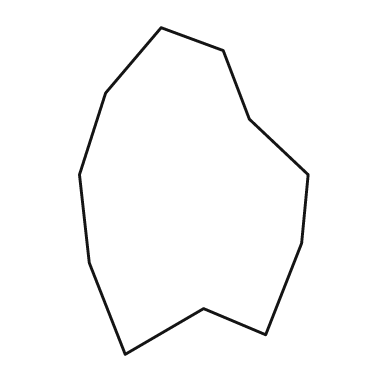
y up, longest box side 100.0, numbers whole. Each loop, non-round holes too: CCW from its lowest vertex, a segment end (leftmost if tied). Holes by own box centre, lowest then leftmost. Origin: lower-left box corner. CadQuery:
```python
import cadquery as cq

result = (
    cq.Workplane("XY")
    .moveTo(14.0, 0.0)
    .lineTo(38.0, 14.0)
    .lineTo(57.0, 6.0)
    .lineTo(68.0, 34.0)
    .lineTo(70.0, 55.0)
    .lineTo(52.0, 72.0)
    .lineTo(44.0, 93.0)
    .lineTo(25.0, 100.0)
    .lineTo(8.0, 80.0)
    .lineTo(0.0, 55.0)
    .lineTo(3.0, 28.0)
    .close()
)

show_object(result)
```